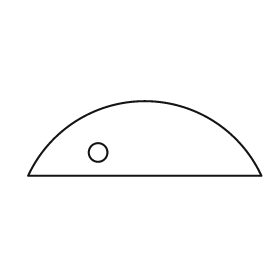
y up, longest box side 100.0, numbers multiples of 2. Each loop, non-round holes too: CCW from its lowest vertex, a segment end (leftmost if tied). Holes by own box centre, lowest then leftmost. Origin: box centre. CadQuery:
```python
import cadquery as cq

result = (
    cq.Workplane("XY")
    .moveTo(-50.0, -16.0)
    .lineTo(50.0, -16.0)
    .threePointArc((0.0, 16.0), (-50.0, -16.0))
    .close()
    .moveTo(-20.0, -6.0)
    .circle(4.0)
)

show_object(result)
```